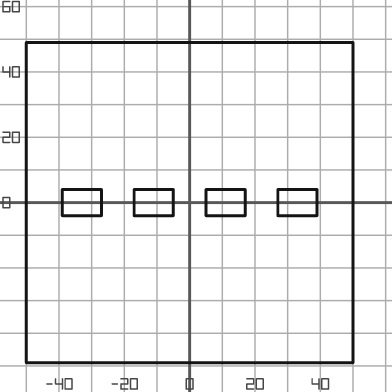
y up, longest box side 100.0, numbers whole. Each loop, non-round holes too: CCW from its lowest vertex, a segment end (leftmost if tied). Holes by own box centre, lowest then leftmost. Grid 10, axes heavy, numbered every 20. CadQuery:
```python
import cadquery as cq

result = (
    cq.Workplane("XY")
    .moveTo(-50.0, -49.0)
    .lineTo(50.0, -49.0)
    .lineTo(50.0, 49.0)
    .lineTo(-50.0, 49.0)
    .close()
    .moveTo(-39.0, -4.0)
    .lineTo(-27.0, -4.0)
    .lineTo(-27.0, 4.0)
    .lineTo(-39.0, 4.0)
    .close()
    .moveTo(-17.0, -4.0)
    .lineTo(-5.0, -4.0)
    .lineTo(-5.0, 4.0)
    .lineTo(-17.0, 4.0)
    .close()
    .moveTo(5.0, -4.0)
    .lineTo(17.0, -4.0)
    .lineTo(17.0, 4.0)
    .lineTo(5.0, 4.0)
    .close()
    .moveTo(27.0, -4.0)
    .lineTo(39.0, -4.0)
    .lineTo(39.0, 4.0)
    .lineTo(27.0, 4.0)
    .close()
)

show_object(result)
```